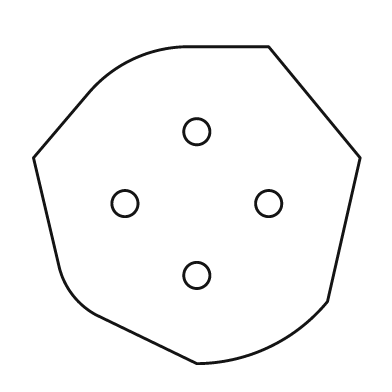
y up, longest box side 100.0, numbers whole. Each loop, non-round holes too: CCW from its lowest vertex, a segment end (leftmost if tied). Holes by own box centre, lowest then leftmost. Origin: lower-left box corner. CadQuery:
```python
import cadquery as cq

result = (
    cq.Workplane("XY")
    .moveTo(50.0, 0.0)
    .threePointArc((72.0, 5.0), (90.0, 19.0))
    .lineTo(100.0, 63.0)
    .lineTo(72.0, 97.0)
    .lineTo(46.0, 97.0)
    .threePointArc((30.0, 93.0), (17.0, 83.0))
    .lineTo(0.0, 63.0)
    .lineTo(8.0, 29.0)
    .threePointArc((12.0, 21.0), (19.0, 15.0))
    .close()
    .moveTo(50.0, 27.0)
    .circle(4.0)
    .moveTo(28.0, 49.0)
    .circle(4.0)
    .moveTo(72.0, 49.0)
    .circle(4.0)
    .moveTo(50.0, 71.0)
    .circle(4.0)
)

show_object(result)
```